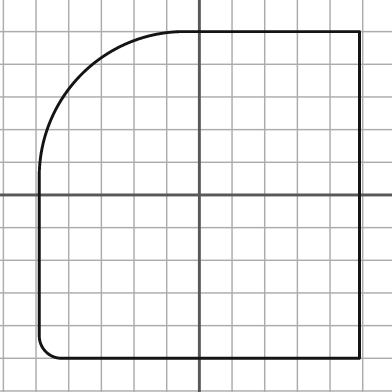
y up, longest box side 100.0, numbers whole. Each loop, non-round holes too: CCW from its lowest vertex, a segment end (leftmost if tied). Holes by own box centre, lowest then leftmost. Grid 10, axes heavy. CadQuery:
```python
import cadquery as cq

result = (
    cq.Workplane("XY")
    .moveTo(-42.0, -50.0)
    .lineTo(49.0, -50.0)
    .lineTo(49.0, 50.0)
    .lineTo(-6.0, 50.0)
    .threePointArc((-36.0, 37.0), (-49.0, 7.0))
    .lineTo(-49.0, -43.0)
    .threePointArc((-47.0, -48.0), (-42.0, -50.0))
    .close()
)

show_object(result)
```